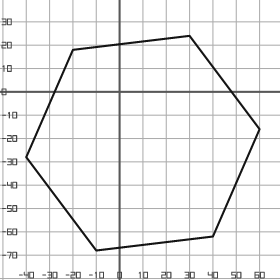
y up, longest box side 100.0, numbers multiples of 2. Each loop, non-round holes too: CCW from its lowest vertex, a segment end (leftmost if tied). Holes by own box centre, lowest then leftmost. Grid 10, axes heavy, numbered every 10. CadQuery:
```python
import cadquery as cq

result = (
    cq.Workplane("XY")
    .moveTo(-10.0, -68.0)
    .lineTo(40.0, -62.0)
    .lineTo(60.0, -16.0)
    .lineTo(30.0, 24.0)
    .lineTo(-20.0, 18.0)
    .lineTo(-40.0, -28.0)
    .close()
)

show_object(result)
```